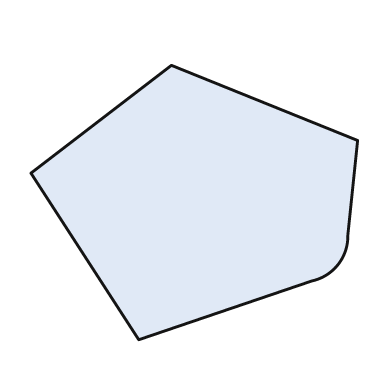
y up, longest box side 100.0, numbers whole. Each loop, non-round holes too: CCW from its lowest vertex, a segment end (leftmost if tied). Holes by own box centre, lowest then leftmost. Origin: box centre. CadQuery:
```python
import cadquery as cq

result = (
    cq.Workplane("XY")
    .moveTo(-17.0, -42.0)
    .lineTo(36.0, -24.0)
    .threePointArc((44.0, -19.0), (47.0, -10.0))
    .lineTo(50.0, 19.0)
    .lineTo(-7.0, 42.0)
    .lineTo(-50.0, 9.0)
    .close()
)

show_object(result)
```